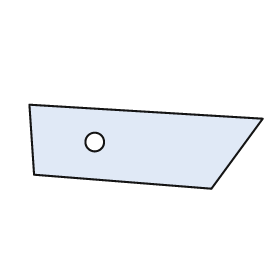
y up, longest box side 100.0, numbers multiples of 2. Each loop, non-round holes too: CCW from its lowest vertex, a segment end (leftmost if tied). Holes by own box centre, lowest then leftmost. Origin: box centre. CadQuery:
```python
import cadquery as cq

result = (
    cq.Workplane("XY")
    .moveTo(28.0, -18.0)
    .lineTo(50.0, 12.0)
    .lineTo(-50.0, 18.0)
    .lineTo(-48.0, -12.0)
    .close()
    .moveTo(-22.0, 2.0)
    .circle(4.0)
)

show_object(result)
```